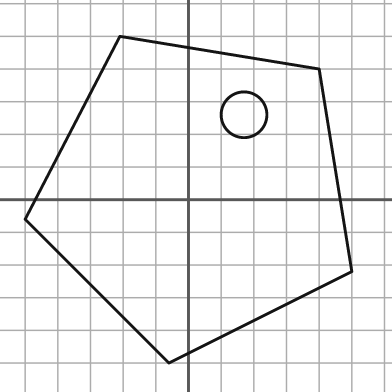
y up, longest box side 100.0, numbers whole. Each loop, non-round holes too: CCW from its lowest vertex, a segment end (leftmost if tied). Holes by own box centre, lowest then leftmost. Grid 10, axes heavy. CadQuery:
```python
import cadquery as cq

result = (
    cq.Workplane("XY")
    .moveTo(-6.0, -50.0)
    .lineTo(50.0, -22.0)
    .lineTo(40.0, 40.0)
    .lineTo(-21.0, 50.0)
    .lineTo(-50.0, -6.0)
    .close()
    .moveTo(17.0, 26.0)
    .circle(7.0)
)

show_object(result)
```